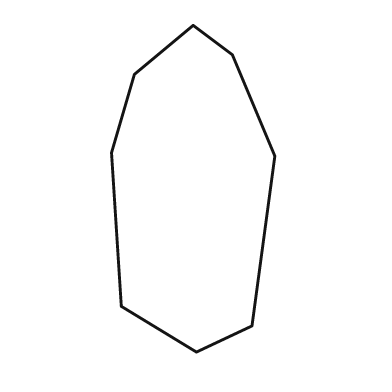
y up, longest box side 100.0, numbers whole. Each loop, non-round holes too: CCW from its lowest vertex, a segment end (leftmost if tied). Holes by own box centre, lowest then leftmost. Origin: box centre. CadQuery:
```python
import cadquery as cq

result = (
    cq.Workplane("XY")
    .moveTo(1.0, -50.0)
    .lineTo(18.0, -42.0)
    .lineTo(25.0, 10.0)
    .lineTo(12.0, 41.0)
    .lineTo(0.0, 50.0)
    .lineTo(-18.0, 35.0)
    .lineTo(-25.0, 11.0)
    .lineTo(-22.0, -36.0)
    .close()
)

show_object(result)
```